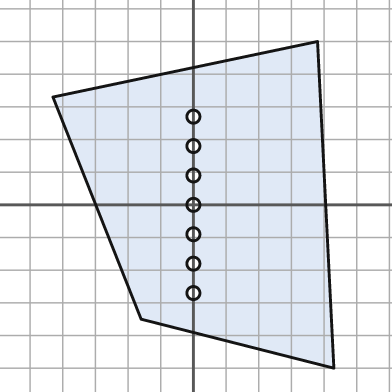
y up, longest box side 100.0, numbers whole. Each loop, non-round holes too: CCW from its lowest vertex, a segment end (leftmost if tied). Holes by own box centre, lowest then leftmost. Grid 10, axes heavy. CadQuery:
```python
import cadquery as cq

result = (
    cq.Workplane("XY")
    .moveTo(43.0, -50.0)
    .lineTo(38.0, 50.0)
    .lineTo(-43.0, 33.0)
    .lineTo(-16.0, -35.0)
    .close()
    .moveTo(0.0, -27.0)
    .circle(2.0)
    .moveTo(0.0, -18.0)
    .circle(2.0)
    .moveTo(0.0, -9.0)
    .circle(2.0)
    .moveTo(0.0, 0.0)
    .circle(2.0)
    .moveTo(0.0, 9.0)
    .circle(2.0)
    .moveTo(0.0, 18.0)
    .circle(2.0)
    .moveTo(0.0, 27.0)
    .circle(2.0)
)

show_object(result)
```